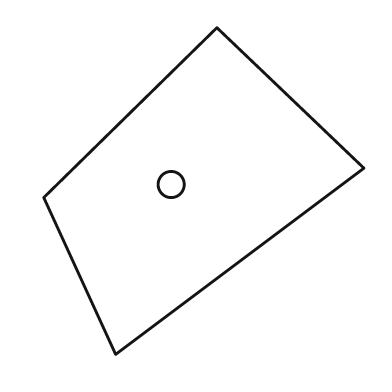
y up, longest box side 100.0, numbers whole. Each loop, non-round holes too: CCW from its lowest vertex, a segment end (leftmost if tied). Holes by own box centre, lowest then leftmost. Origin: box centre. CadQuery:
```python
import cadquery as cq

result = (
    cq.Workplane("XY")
    .moveTo(-27.0, -50.0)
    .lineTo(49.0, 7.0)
    .lineTo(4.0, 50.0)
    .lineTo(-49.0, -2.0)
    .close()
    .moveTo(-10.0, 2.0)
    .circle(4.0)
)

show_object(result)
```